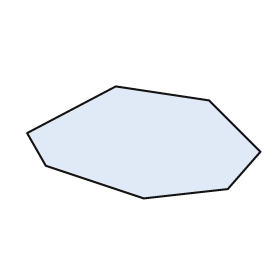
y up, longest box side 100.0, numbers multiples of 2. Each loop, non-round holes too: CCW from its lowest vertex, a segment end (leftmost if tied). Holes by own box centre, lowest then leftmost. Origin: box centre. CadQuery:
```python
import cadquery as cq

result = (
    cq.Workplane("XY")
    .moveTo(0.0, -24.0)
    .lineTo(36.0, -20.0)
    .lineTo(50.0, -4.0)
    .lineTo(28.0, 18.0)
    .lineTo(-12.0, 24.0)
    .lineTo(-50.0, 4.0)
    .lineTo(-42.0, -10.0)
    .close()
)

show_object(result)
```